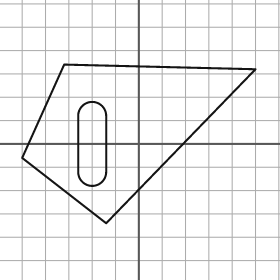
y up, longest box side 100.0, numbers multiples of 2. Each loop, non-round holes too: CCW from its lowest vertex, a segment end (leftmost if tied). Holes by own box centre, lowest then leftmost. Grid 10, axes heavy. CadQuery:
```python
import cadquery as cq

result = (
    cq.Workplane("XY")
    .moveTo(-14.0, -34.0)
    .lineTo(50.0, 32.0)
    .lineTo(-32.0, 34.0)
    .lineTo(-50.0, -6.0)
    .close()
    .moveTo(-26.0, -12.0)
    .threePointArc((-20.0, -18.0), (-14.0, -12.0))
    .lineTo(-14.0, 12.0)
    .threePointArc((-20.0, 18.0), (-26.0, 12.0))
    .close()
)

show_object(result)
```